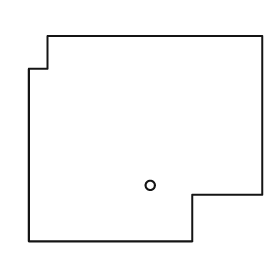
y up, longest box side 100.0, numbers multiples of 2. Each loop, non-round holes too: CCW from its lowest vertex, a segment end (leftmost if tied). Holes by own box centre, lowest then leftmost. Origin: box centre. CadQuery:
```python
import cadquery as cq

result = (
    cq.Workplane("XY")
    .moveTo(-50.0, -44.0)
    .lineTo(20.0, -44.0)
    .lineTo(20.0, -24.0)
    .lineTo(50.0, -24.0)
    .lineTo(50.0, 44.0)
    .lineTo(-42.0, 44.0)
    .lineTo(-42.0, 30.0)
    .lineTo(-50.0, 30.0)
    .close()
    .moveTo(2.0, -20.0)
    .circle(2.0)
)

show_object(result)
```